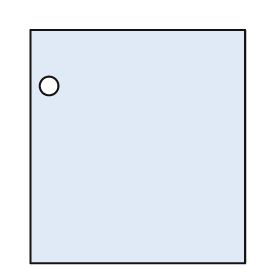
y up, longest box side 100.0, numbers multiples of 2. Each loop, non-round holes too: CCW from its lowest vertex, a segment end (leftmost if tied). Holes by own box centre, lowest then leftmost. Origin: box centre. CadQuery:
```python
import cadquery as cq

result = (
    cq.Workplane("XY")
    .moveTo(-46.0, -50.0)
    .lineTo(46.0, -50.0)
    .lineTo(46.0, 50.0)
    .lineTo(-46.0, 50.0)
    .close()
    .moveTo(-38.0, 26.0)
    .circle(4.0)
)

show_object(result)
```